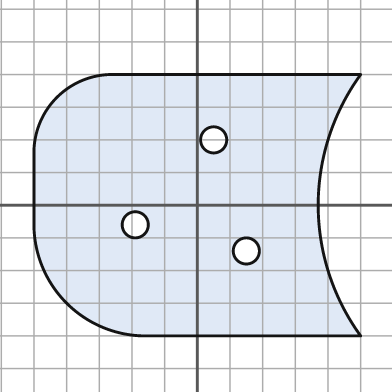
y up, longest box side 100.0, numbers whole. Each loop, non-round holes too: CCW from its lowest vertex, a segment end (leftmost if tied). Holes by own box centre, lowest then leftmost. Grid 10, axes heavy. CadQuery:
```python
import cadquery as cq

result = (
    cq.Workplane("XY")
    .moveTo(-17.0, -40.0)
    .lineTo(50.0, -40.0)
    .threePointArc((37.0, 0.0), (50.0, 40.0))
    .lineTo(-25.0, 40.0)
    .threePointArc((-43.0, 33.0), (-50.0, 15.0))
    .lineTo(-50.0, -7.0)
    .threePointArc((-40.0, -30.0), (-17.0, -40.0))
    .close()
    .moveTo(15.0, -14.0)
    .circle(4.0)
    .moveTo(-19.0, -6.0)
    .circle(4.0)
    .moveTo(5.0, 20.0)
    .circle(4.0)
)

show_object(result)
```